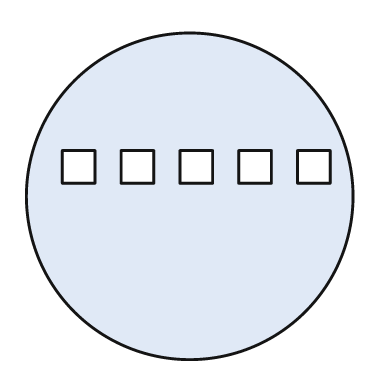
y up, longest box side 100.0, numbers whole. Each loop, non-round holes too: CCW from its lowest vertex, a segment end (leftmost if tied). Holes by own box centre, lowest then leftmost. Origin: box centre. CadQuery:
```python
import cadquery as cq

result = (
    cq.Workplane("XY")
    .moveTo(0.0, 0.0)
    .circle(50.0)
    .moveTo(-39.0, 4.0)
    .lineTo(-29.0, 4.0)
    .lineTo(-29.0, 14.0)
    .lineTo(-39.0, 14.0)
    .close()
    .moveTo(-21.0, 4.0)
    .lineTo(-11.0, 4.0)
    .lineTo(-11.0, 14.0)
    .lineTo(-21.0, 14.0)
    .close()
    .moveTo(-3.0, 4.0)
    .lineTo(7.0, 4.0)
    .lineTo(7.0, 14.0)
    .lineTo(-3.0, 14.0)
    .close()
    .moveTo(15.0, 4.0)
    .lineTo(25.0, 4.0)
    .lineTo(25.0, 14.0)
    .lineTo(15.0, 14.0)
    .close()
    .moveTo(33.0, 4.0)
    .lineTo(43.0, 4.0)
    .lineTo(43.0, 14.0)
    .lineTo(33.0, 14.0)
    .close()
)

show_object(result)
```